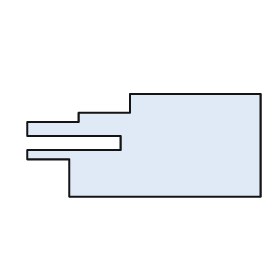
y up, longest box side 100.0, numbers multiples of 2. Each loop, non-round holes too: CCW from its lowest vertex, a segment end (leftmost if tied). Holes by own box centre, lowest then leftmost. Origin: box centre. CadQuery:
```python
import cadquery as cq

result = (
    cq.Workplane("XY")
    .moveTo(-32.0, -22.0)
    .lineTo(50.0, -22.0)
    .lineTo(50.0, 22.0)
    .lineTo(-6.0, 22.0)
    .lineTo(-6.0, 14.0)
    .lineTo(-28.0, 14.0)
    .lineTo(-28.0, 10.0)
    .lineTo(-50.0, 10.0)
    .lineTo(-50.0, 4.0)
    .lineTo(-10.0, 4.0)
    .lineTo(-10.0, -2.0)
    .lineTo(-50.0, -2.0)
    .lineTo(-50.0, -6.0)
    .lineTo(-32.0, -6.0)
    .close()
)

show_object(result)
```